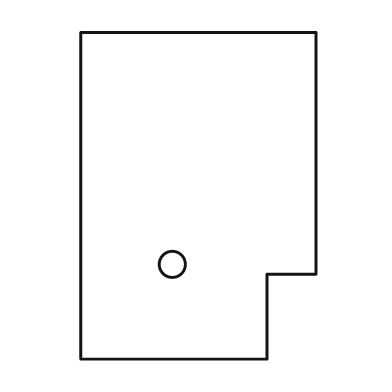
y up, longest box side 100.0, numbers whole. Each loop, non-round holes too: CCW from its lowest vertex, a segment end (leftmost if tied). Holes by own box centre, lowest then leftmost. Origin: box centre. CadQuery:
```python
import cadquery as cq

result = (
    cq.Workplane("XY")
    .moveTo(-36.0, -50.0)
    .lineTo(21.0, -50.0)
    .lineTo(21.0, -24.0)
    .lineTo(36.0, -24.0)
    .lineTo(36.0, 50.0)
    .lineTo(-36.0, 50.0)
    .close()
    .moveTo(-8.0, -21.0)
    .circle(4.0)
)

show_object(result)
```